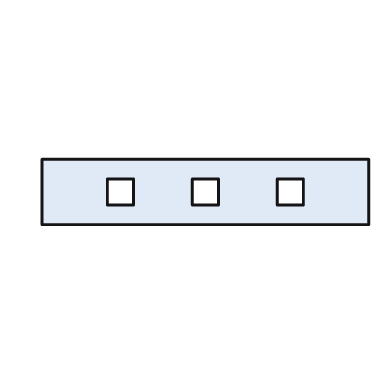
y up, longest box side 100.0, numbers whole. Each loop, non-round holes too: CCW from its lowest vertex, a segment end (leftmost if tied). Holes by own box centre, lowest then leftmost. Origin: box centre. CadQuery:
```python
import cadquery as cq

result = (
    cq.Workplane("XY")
    .moveTo(-50.0, -10.0)
    .lineTo(50.0, -10.0)
    .lineTo(50.0, 10.0)
    .lineTo(-50.0, 10.0)
    .close()
    .moveTo(-30.0, -4.0)
    .lineTo(-22.0, -4.0)
    .lineTo(-22.0, 4.0)
    .lineTo(-30.0, 4.0)
    .close()
    .moveTo(-4.0, -4.0)
    .lineTo(4.0, -4.0)
    .lineTo(4.0, 4.0)
    .lineTo(-4.0, 4.0)
    .close()
    .moveTo(22.0, -4.0)
    .lineTo(30.0, -4.0)
    .lineTo(30.0, 4.0)
    .lineTo(22.0, 4.0)
    .close()
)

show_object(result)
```